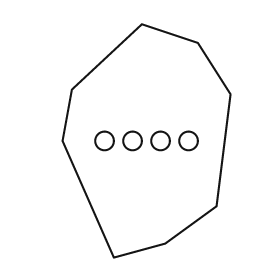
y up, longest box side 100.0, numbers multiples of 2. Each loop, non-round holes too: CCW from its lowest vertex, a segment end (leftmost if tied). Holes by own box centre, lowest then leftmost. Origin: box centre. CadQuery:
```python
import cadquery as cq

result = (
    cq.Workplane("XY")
    .moveTo(-14.0, -50.0)
    .lineTo(8.0, -44.0)
    .lineTo(30.0, -28.0)
    .lineTo(36.0, 20.0)
    .lineTo(22.0, 42.0)
    .lineTo(-2.0, 50.0)
    .lineTo(-32.0, 22.0)
    .lineTo(-36.0, 0.0)
    .close()
    .moveTo(-18.0, 0.0)
    .circle(4.0)
    .moveTo(-6.0, 0.0)
    .circle(4.0)
    .moveTo(6.0, 0.0)
    .circle(4.0)
    .moveTo(18.0, 0.0)
    .circle(4.0)
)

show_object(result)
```